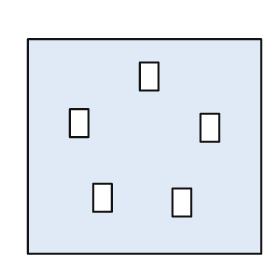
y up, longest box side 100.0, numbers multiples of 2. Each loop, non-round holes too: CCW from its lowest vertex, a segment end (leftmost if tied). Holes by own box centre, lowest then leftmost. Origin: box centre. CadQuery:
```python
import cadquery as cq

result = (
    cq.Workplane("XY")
    .moveTo(-50.0, -46.0)
    .lineTo(50.0, -46.0)
    .lineTo(50.0, 46.0)
    .lineTo(-50.0, 46.0)
    .close()
    .moveTo(12.0, -30.0)
    .lineTo(20.0, -30.0)
    .lineTo(20.0, -18.0)
    .lineTo(12.0, -18.0)
    .close()
    .moveTo(-22.0, -28.0)
    .lineTo(-14.0, -28.0)
    .lineTo(-14.0, -16.0)
    .lineTo(-22.0, -16.0)
    .close()
    .moveTo(24.0, 2.0)
    .lineTo(32.0, 2.0)
    .lineTo(32.0, 14.0)
    .lineTo(24.0, 14.0)
    .close()
    .moveTo(-32.0, 4.0)
    .lineTo(-24.0, 4.0)
    .lineTo(-24.0, 16.0)
    .lineTo(-32.0, 16.0)
    .close()
    .moveTo(-2.0, 24.0)
    .lineTo(6.0, 24.0)
    .lineTo(6.0, 36.0)
    .lineTo(-2.0, 36.0)
    .close()
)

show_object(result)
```